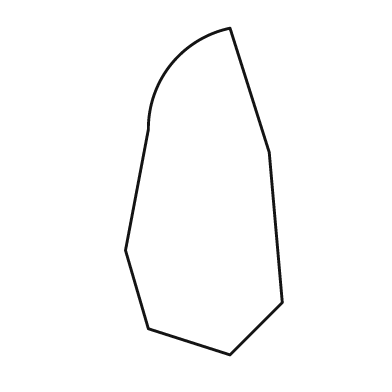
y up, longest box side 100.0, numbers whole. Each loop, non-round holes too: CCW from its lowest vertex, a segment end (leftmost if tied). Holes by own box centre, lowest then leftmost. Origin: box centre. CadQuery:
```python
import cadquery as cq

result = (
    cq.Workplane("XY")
    .moveTo(8.0, -50.0)
    .lineTo(24.0, -34.0)
    .lineTo(20.0, 12.0)
    .lineTo(8.0, 50.0)
    .threePointArc((-10.0, 39.0), (-17.0, 19.0))
    .lineTo(-24.0, -18.0)
    .lineTo(-17.0, -42.0)
    .close()
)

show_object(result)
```